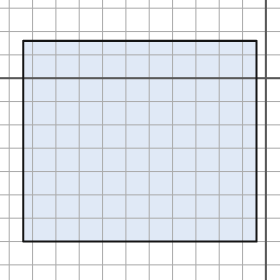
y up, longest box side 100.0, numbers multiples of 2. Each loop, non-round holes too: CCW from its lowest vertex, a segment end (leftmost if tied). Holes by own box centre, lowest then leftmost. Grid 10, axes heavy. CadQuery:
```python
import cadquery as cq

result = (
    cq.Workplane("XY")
    .moveTo(-104.0, -70.0)
    .lineTo(-4.0, -70.0)
    .lineTo(-4.0, 16.0)
    .lineTo(-104.0, 16.0)
    .close()
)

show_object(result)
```